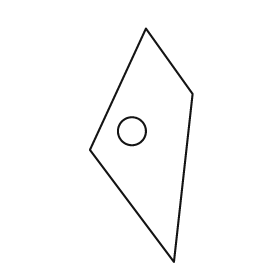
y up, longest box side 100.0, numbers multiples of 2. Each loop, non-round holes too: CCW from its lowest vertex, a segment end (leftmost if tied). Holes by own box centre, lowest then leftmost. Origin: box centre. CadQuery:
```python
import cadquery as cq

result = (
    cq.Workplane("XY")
    .moveTo(14.0, -50.0)
    .lineTo(22.0, 22.0)
    .lineTo(2.0, 50.0)
    .lineTo(-22.0, -2.0)
    .close()
    .moveTo(-4.0, 6.0)
    .circle(6.0)
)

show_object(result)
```